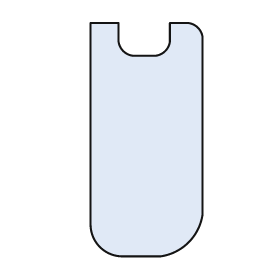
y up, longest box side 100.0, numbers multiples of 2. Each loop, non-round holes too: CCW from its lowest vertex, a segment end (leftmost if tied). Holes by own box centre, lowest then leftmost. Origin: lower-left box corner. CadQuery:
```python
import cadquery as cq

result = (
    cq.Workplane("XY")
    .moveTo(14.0, 0.0)
    .lineTo(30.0, 0.0)
    .threePointArc((42.0, 6.0), (48.0, 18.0))
    .lineTo(48.0, 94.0)
    .threePointArc((46.0, 98.0), (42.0, 100.0))
    .lineTo(34.0, 100.0)
    .lineTo(34.0, 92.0)
    .threePointArc((32.0, 88.0), (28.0, 86.0))
    .lineTo(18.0, 86.0)
    .threePointArc((14.0, 88.0), (12.0, 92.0))
    .lineTo(12.0, 100.0)
    .lineTo(0.0, 100.0)
    .lineTo(0.0, 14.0)
    .threePointArc((4.0, 4.0), (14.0, 0.0))
    .close()
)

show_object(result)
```